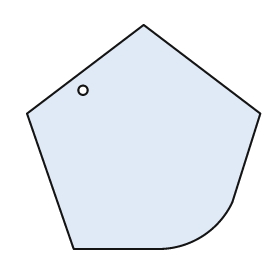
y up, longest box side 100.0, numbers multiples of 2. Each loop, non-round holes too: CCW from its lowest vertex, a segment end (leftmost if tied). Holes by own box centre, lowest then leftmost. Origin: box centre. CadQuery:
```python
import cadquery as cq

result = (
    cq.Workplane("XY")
    .moveTo(-30.0, -48.0)
    .lineTo(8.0, -48.0)
    .threePointArc((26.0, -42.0), (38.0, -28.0))
    .lineTo(50.0, 10.0)
    .lineTo(0.0, 48.0)
    .lineTo(-50.0, 10.0)
    .close()
    .moveTo(-26.0, 20.0)
    .circle(2.0)
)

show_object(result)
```